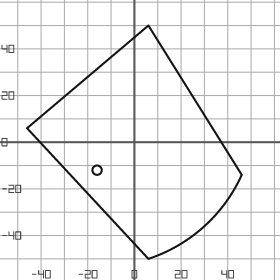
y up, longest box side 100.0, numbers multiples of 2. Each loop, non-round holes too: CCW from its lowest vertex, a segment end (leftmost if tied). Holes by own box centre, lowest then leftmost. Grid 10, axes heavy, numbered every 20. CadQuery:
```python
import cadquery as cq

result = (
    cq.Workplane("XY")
    .moveTo(6.0, -50.0)
    .threePointArc((30.0, -36.0), (46.0, -14.0))
    .lineTo(6.0, 50.0)
    .lineTo(-46.0, 6.0)
    .close()
    .moveTo(-16.0, -12.0)
    .circle(2.0)
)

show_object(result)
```